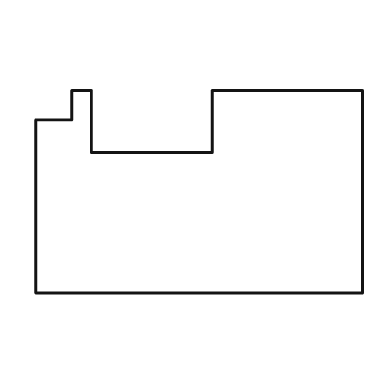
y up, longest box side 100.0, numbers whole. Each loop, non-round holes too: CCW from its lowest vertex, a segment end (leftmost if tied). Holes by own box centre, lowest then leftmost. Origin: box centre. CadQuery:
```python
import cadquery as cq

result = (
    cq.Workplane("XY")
    .moveTo(-50.0, -31.0)
    .lineTo(50.0, -31.0)
    .lineTo(50.0, 31.0)
    .lineTo(4.0, 31.0)
    .lineTo(4.0, 12.0)
    .lineTo(-33.0, 12.0)
    .lineTo(-33.0, 31.0)
    .lineTo(-39.0, 31.0)
    .lineTo(-39.0, 22.0)
    .lineTo(-50.0, 22.0)
    .close()
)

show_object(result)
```